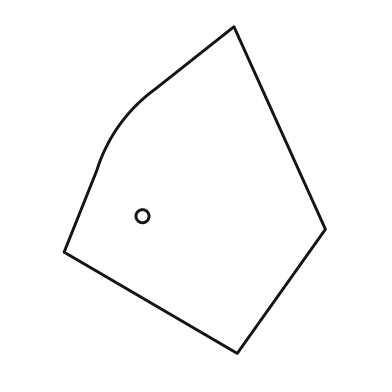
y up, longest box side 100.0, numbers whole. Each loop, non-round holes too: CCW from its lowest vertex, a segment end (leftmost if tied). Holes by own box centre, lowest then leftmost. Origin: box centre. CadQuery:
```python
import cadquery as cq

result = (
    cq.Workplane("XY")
    .moveTo(13.0, -50.0)
    .lineTo(40.0, -12.0)
    .lineTo(12.0, 50.0)
    .lineTo(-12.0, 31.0)
    .threePointArc((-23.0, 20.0), (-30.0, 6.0))
    .lineTo(-40.0, -19.0)
    .close()
    .moveTo(-16.0, -8.0)
    .circle(2.0)
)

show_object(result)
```